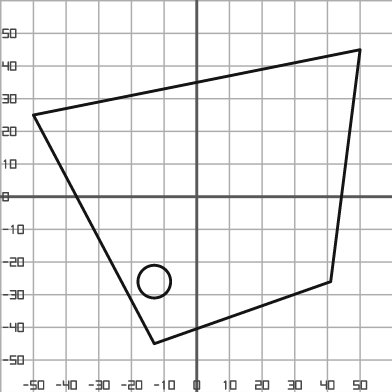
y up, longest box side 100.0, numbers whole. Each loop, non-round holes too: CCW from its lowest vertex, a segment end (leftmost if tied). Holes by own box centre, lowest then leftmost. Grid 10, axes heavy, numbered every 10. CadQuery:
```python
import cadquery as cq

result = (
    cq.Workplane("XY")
    .moveTo(-13.0, -45.0)
    .lineTo(41.0, -26.0)
    .lineTo(50.0, 45.0)
    .lineTo(-50.0, 25.0)
    .close()
    .moveTo(-13.0, -26.0)
    .circle(5.0)
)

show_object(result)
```